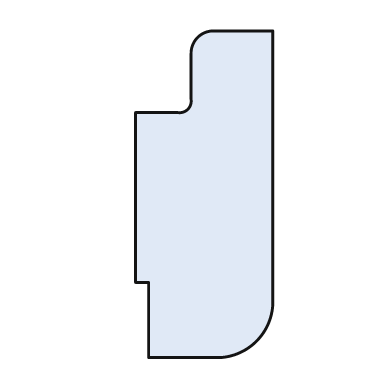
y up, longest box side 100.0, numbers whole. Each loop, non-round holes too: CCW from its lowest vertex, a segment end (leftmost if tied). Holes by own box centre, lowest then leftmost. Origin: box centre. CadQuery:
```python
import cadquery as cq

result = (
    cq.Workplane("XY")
    .moveTo(-17.0, -50.0)
    .lineTo(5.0, -50.0)
    .threePointArc((16.0, -45.0), (21.0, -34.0))
    .lineTo(21.0, 50.0)
    .lineTo(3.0, 50.0)
    .threePointArc((-2.0, 48.0), (-4.0, 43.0))
    .lineTo(-4.0, 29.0)
    .threePointArc((-5.0, 26.0), (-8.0, 25.0))
    .lineTo(-21.0, 25.0)
    .lineTo(-21.0, -27.0)
    .lineTo(-17.0, -27.0)
    .close()
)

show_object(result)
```